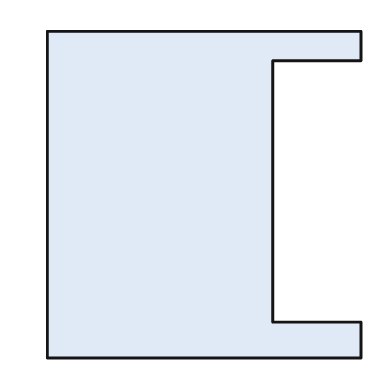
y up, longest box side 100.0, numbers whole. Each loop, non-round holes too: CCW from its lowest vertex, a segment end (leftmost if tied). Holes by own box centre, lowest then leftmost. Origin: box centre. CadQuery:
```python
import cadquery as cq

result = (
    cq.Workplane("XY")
    .moveTo(-48.0, -50.0)
    .lineTo(48.0, -50.0)
    .lineTo(48.0, -39.0)
    .lineTo(21.0, -39.0)
    .lineTo(21.0, 41.0)
    .lineTo(48.0, 41.0)
    .lineTo(48.0, 50.0)
    .lineTo(-48.0, 50.0)
    .close()
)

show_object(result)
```